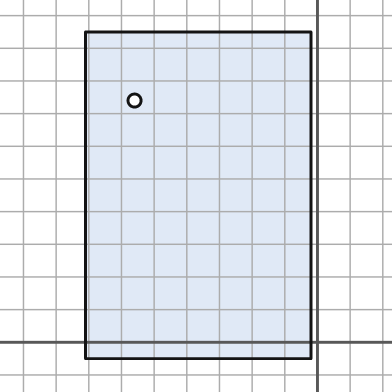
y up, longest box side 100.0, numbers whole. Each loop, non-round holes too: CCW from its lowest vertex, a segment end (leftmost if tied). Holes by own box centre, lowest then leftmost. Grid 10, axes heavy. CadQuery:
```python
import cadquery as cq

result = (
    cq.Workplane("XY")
    .moveTo(-71.0, -5.0)
    .lineTo(-2.0, -5.0)
    .lineTo(-2.0, 95.0)
    .lineTo(-71.0, 95.0)
    .close()
    .moveTo(-56.0, 74.0)
    .circle(2.0)
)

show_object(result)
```